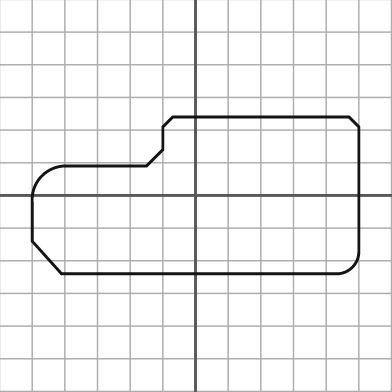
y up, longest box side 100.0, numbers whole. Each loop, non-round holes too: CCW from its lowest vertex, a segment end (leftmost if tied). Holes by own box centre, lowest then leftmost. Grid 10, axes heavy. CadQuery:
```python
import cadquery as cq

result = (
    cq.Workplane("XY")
    .moveTo(-41.0, -24.0)
    .lineTo(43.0, -24.0)
    .threePointArc((48.0, -22.0), (50.0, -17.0))
    .lineTo(50.0, 21.0)
    .lineTo(47.0, 24.0)
    .lineTo(-7.0, 24.0)
    .lineTo(-10.0, 21.0)
    .lineTo(-10.0, 14.0)
    .lineTo(-15.0, 9.0)
    .lineTo(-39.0, 9.0)
    .threePointArc((-47.0, 6.0), (-50.0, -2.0))
    .lineTo(-50.0, -14.0)
    .close()
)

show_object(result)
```